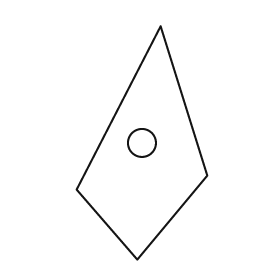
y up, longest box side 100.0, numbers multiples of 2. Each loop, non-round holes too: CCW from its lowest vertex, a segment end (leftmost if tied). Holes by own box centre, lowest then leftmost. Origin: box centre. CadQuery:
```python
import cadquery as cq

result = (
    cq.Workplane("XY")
    .moveTo(-2.0, -50.0)
    .lineTo(28.0, -14.0)
    .lineTo(8.0, 50.0)
    .lineTo(-28.0, -20.0)
    .close()
    .moveTo(0.0, 0.0)
    .circle(6.0)
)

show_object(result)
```